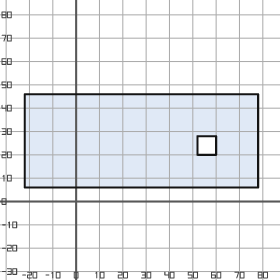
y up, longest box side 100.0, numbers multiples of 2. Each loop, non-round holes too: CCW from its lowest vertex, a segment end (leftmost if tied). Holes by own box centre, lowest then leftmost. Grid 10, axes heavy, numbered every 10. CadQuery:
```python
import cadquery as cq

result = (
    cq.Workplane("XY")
    .moveTo(-22.0, 6.0)
    .lineTo(78.0, 6.0)
    .lineTo(78.0, 46.0)
    .lineTo(-22.0, 46.0)
    .close()
    .moveTo(52.0, 20.0)
    .lineTo(60.0, 20.0)
    .lineTo(60.0, 28.0)
    .lineTo(52.0, 28.0)
    .close()
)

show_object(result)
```